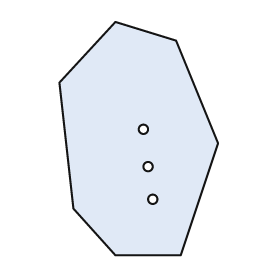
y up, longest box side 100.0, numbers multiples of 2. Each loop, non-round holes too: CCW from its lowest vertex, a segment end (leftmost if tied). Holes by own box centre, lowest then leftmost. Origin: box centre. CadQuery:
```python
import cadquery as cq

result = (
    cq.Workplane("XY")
    .moveTo(-10.0, -50.0)
    .lineTo(18.0, -50.0)
    .lineTo(34.0, -2.0)
    .lineTo(16.0, 42.0)
    .lineTo(-10.0, 50.0)
    .lineTo(-34.0, 24.0)
    .lineTo(-28.0, -30.0)
    .close()
    .moveTo(6.0, -26.0)
    .circle(2.0)
    .moveTo(4.0, -12.0)
    .circle(2.0)
    .moveTo(2.0, 4.0)
    .circle(2.0)
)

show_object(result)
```